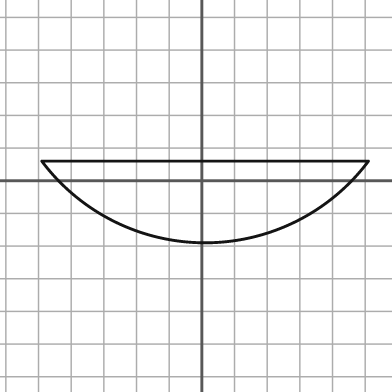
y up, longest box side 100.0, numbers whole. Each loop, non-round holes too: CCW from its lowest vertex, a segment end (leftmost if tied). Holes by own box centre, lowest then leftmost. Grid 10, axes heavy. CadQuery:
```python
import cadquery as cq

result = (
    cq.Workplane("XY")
    .moveTo(-49.0, 6.0)
    .threePointArc((1.0, -19.0), (51.0, 6.0))
    .close()
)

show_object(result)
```